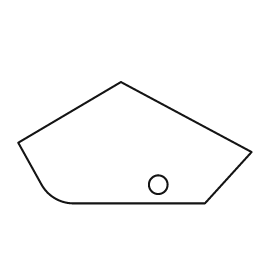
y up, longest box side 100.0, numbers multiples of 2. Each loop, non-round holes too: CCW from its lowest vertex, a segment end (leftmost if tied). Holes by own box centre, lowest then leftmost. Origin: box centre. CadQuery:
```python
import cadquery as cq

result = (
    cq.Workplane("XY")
    .moveTo(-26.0, -26.0)
    .lineTo(30.0, -26.0)
    .lineTo(50.0, -4.0)
    .lineTo(-6.0, 26.0)
    .lineTo(-50.0, 0.0)
    .lineTo(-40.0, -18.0)
    .threePointArc((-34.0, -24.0), (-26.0, -26.0))
    .close()
    .moveTo(10.0, -18.0)
    .circle(4.0)
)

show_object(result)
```